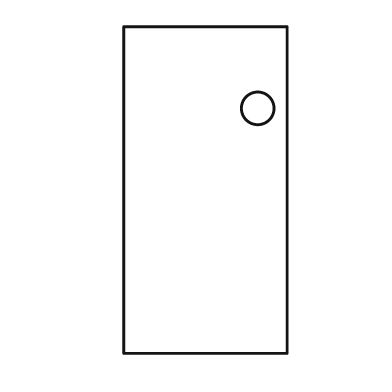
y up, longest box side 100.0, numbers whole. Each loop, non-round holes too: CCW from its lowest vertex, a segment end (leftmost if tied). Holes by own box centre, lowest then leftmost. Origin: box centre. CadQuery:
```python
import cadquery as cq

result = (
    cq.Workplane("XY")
    .moveTo(-25.0, -50.0)
    .lineTo(25.0, -50.0)
    .lineTo(25.0, 50.0)
    .lineTo(-25.0, 50.0)
    .close()
    .moveTo(16.0, 25.0)
    .circle(5.0)
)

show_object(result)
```